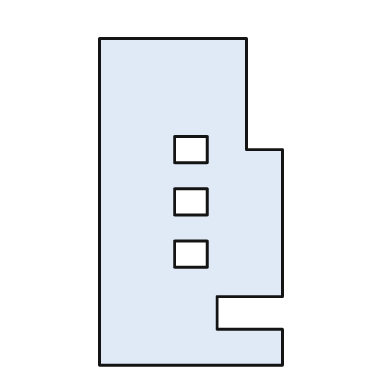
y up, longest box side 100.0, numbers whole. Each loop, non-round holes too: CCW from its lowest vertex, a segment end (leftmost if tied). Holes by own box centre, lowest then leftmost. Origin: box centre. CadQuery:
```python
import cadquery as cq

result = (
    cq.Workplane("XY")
    .moveTo(-28.0, -50.0)
    .lineTo(28.0, -50.0)
    .lineTo(28.0, -39.0)
    .lineTo(8.0, -39.0)
    .lineTo(8.0, -29.0)
    .lineTo(28.0, -29.0)
    .lineTo(28.0, 16.0)
    .lineTo(17.0, 16.0)
    .lineTo(17.0, 50.0)
    .lineTo(-28.0, 50.0)
    .close()
    .moveTo(-5.0, -20.0)
    .lineTo(5.0, -20.0)
    .lineTo(5.0, -12.0)
    .lineTo(-5.0, -12.0)
    .close()
    .moveTo(-5.0, -4.0)
    .lineTo(5.0, -4.0)
    .lineTo(5.0, 4.0)
    .lineTo(-5.0, 4.0)
    .close()
    .moveTo(-5.0, 12.0)
    .lineTo(5.0, 12.0)
    .lineTo(5.0, 20.0)
    .lineTo(-5.0, 20.0)
    .close()
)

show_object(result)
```